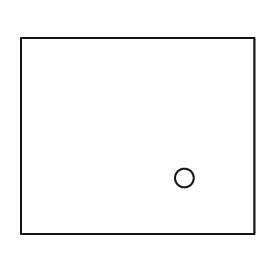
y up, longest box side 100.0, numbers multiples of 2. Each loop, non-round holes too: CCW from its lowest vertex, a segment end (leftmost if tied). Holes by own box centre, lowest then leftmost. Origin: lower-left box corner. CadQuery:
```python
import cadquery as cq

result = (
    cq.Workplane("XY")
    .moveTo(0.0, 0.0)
    .lineTo(100.0, 0.0)
    .lineTo(100.0, 84.0)
    .lineTo(0.0, 84.0)
    .close()
    .moveTo(70.0, 24.0)
    .circle(4.0)
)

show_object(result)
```